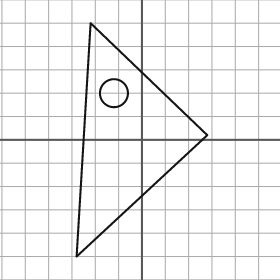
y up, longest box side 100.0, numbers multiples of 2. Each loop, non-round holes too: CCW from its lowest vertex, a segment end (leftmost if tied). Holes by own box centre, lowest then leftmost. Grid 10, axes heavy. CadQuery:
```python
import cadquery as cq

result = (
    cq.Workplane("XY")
    .moveTo(-28.0, -50.0)
    .lineTo(28.0, 2.0)
    .lineTo(-22.0, 50.0)
    .close()
    .moveTo(-12.0, 20.0)
    .circle(6.0)
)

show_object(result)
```